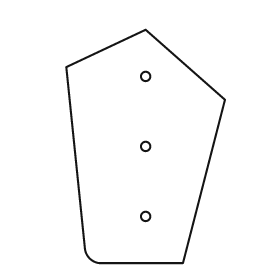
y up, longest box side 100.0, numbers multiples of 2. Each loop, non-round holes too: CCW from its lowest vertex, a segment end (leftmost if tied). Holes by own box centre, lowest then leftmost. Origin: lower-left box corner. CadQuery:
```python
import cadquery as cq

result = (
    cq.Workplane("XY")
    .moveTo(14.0, 0.0)
    .lineTo(50.0, 0.0)
    .lineTo(68.0, 70.0)
    .lineTo(34.0, 100.0)
    .lineTo(0.0, 84.0)
    .lineTo(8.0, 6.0)
    .threePointArc((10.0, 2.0), (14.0, 0.0))
    .close()
    .moveTo(34.0, 20.0)
    .circle(2.0)
    .moveTo(34.0, 50.0)
    .circle(2.0)
    .moveTo(34.0, 80.0)
    .circle(2.0)
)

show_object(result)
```